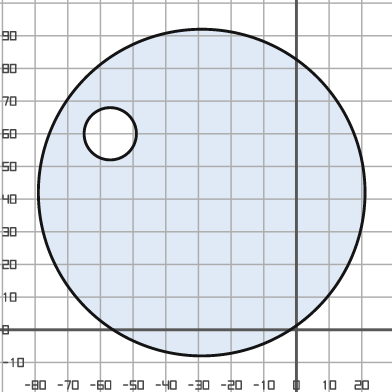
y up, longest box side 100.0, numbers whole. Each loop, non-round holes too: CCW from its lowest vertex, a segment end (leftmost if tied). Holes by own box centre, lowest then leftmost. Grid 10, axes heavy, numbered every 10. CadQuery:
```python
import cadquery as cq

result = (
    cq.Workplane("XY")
    .moveTo(-29.0, 42.0)
    .circle(50.0)
    .moveTo(-57.0, 60.0)
    .circle(8.0)
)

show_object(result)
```